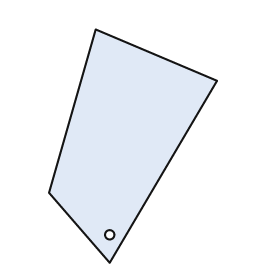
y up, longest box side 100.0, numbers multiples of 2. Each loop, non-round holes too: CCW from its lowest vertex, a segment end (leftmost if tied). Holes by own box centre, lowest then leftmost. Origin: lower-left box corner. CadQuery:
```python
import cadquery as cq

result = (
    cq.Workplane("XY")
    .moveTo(26.0, 0.0)
    .lineTo(72.0, 78.0)
    .lineTo(20.0, 100.0)
    .lineTo(0.0, 30.0)
    .close()
    .moveTo(26.0, 12.0)
    .circle(2.0)
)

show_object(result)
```